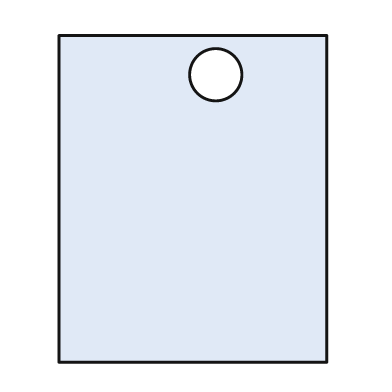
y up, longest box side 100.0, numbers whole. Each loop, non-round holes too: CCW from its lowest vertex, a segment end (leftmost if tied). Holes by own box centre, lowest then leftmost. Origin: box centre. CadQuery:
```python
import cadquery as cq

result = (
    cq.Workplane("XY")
    .moveTo(-41.0, -50.0)
    .lineTo(41.0, -50.0)
    .lineTo(41.0, 50.0)
    .lineTo(-41.0, 50.0)
    .close()
    .moveTo(7.0, 38.0)
    .circle(8.0)
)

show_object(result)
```